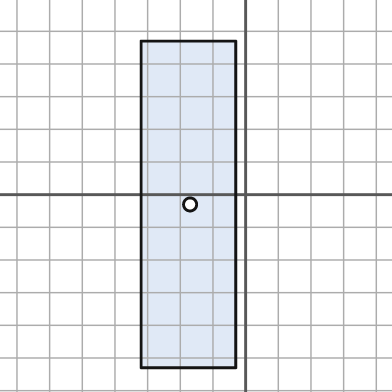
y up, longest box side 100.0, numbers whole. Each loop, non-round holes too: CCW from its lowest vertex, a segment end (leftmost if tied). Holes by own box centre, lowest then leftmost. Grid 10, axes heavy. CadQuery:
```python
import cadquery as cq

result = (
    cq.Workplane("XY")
    .moveTo(-32.0, -53.0)
    .lineTo(-3.0, -53.0)
    .lineTo(-3.0, 47.0)
    .lineTo(-32.0, 47.0)
    .close()
    .moveTo(-17.0, -3.0)
    .circle(2.0)
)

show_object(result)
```